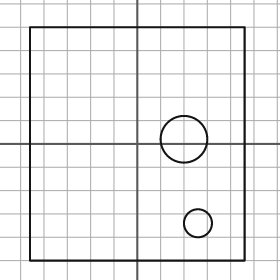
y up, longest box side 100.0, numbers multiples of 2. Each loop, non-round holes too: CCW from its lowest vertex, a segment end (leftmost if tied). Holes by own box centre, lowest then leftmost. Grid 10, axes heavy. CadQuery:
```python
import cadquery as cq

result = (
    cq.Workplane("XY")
    .moveTo(-46.0, -50.0)
    .lineTo(46.0, -50.0)
    .lineTo(46.0, 50.0)
    .lineTo(-46.0, 50.0)
    .close()
    .moveTo(26.0, -34.0)
    .circle(6.0)
    .moveTo(20.0, 2.0)
    .circle(10.0)
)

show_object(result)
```